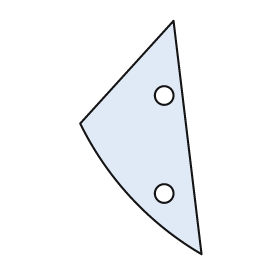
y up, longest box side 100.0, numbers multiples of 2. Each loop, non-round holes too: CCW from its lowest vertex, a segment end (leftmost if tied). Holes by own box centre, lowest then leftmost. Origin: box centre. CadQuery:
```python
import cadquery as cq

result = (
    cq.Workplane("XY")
    .moveTo(26.0, -50.0)
    .lineTo(14.0, 50.0)
    .lineTo(-26.0, 6.0)
    .threePointArc((-4.0, -26.0), (26.0, -50.0))
    .close()
    .moveTo(10.0, -24.0)
    .circle(4.0)
    .moveTo(10.0, 18.0)
    .circle(4.0)
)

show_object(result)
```